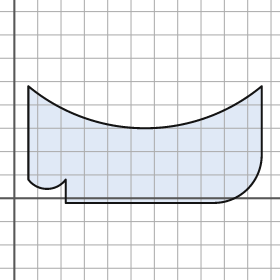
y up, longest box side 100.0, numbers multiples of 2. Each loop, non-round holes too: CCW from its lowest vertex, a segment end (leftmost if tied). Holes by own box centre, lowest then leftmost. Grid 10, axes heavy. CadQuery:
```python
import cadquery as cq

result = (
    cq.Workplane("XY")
    .moveTo(22.0, -2.0)
    .lineTo(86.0, -2.0)
    .threePointArc((100.0, 4.0), (106.0, 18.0))
    .lineTo(106.0, 48.0)
    .threePointArc((56.0, 30.0), (6.0, 48.0))
    .lineTo(6.0, 8.0)
    .threePointArc((14.0, 4.0), (22.0, 8.0))
    .close()
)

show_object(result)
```